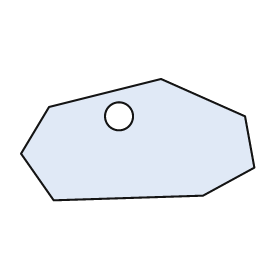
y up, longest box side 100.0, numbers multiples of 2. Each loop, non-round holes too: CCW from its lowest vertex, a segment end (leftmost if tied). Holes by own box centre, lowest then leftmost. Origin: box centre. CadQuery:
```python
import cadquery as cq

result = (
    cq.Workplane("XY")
    .moveTo(-36.0, -26.0)
    .lineTo(28.0, -24.0)
    .lineTo(50.0, -12.0)
    .lineTo(46.0, 10.0)
    .lineTo(10.0, 26.0)
    .lineTo(-38.0, 14.0)
    .lineTo(-50.0, -6.0)
    .close()
    .moveTo(-8.0, 10.0)
    .circle(6.0)
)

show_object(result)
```